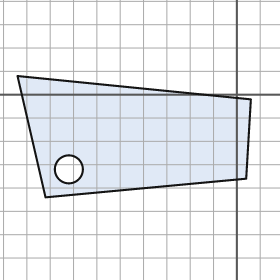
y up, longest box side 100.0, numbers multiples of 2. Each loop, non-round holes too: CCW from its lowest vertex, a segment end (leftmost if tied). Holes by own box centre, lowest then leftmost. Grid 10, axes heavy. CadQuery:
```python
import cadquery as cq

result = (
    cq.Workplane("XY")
    .moveTo(-82.0, -44.0)
    .lineTo(4.0, -36.0)
    .lineTo(6.0, -2.0)
    .lineTo(-94.0, 8.0)
    .close()
    .moveTo(-72.0, -32.0)
    .circle(6.0)
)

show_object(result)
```